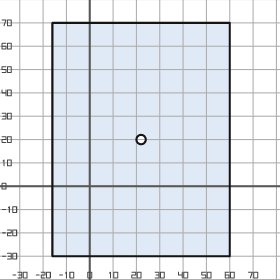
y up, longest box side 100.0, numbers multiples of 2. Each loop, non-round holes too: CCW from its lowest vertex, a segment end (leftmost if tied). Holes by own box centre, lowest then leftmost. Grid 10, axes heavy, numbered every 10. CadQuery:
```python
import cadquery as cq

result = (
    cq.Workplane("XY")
    .moveTo(-16.0, -30.0)
    .lineTo(60.0, -30.0)
    .lineTo(60.0, 70.0)
    .lineTo(-16.0, 70.0)
    .close()
    .moveTo(22.0, 20.0)
    .circle(2.0)
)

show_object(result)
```